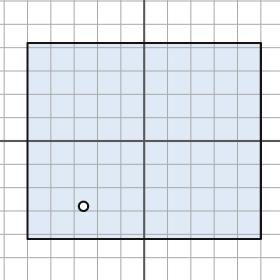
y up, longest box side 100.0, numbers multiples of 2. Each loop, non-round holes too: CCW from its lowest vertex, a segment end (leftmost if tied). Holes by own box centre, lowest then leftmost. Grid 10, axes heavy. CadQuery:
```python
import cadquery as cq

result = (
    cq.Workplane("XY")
    .moveTo(-50.0, -42.0)
    .lineTo(50.0, -42.0)
    .lineTo(50.0, 42.0)
    .lineTo(-50.0, 42.0)
    .close()
    .moveTo(-26.0, -28.0)
    .circle(2.0)
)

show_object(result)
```